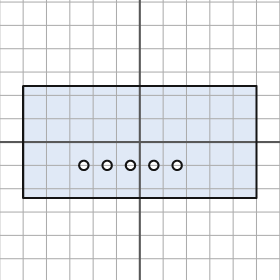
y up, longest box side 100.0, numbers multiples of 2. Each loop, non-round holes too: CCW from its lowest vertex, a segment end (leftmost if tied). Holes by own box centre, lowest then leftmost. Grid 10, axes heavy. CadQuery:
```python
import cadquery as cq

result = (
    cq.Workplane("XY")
    .moveTo(-50.0, -24.0)
    .lineTo(50.0, -24.0)
    .lineTo(50.0, 24.0)
    .lineTo(-50.0, 24.0)
    .close()
    .moveTo(-24.0, -10.0)
    .circle(2.0)
    .moveTo(-14.0, -10.0)
    .circle(2.0)
    .moveTo(-4.0, -10.0)
    .circle(2.0)
    .moveTo(6.0, -10.0)
    .circle(2.0)
    .moveTo(16.0, -10.0)
    .circle(2.0)
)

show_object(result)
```